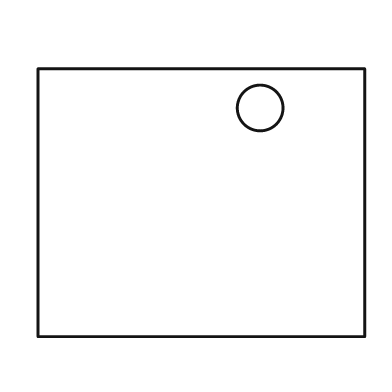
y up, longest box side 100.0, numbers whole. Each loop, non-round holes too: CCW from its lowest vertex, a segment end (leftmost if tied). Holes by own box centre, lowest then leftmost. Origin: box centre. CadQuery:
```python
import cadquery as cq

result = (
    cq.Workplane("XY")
    .moveTo(-50.0, -41.0)
    .lineTo(50.0, -41.0)
    .lineTo(50.0, 41.0)
    .lineTo(-50.0, 41.0)
    .close()
    .moveTo(18.0, 29.0)
    .circle(7.0)
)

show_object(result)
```